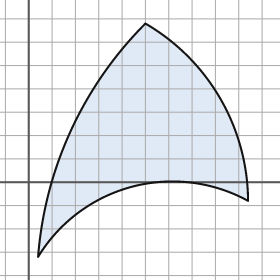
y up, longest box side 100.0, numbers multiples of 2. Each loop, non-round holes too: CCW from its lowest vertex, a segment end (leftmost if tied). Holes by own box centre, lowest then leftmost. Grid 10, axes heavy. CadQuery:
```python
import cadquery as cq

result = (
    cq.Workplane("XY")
    .moveTo(4.0, -32.0)
    .threePointArc((44.0, -2.0), (94.0, -8.0))
    .threePointArc((82.0, 36.0), (50.0, 68.0))
    .threePointArc((18.0, 22.0), (4.0, -32.0))
    .close()
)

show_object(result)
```